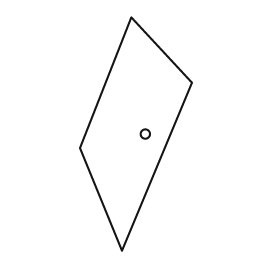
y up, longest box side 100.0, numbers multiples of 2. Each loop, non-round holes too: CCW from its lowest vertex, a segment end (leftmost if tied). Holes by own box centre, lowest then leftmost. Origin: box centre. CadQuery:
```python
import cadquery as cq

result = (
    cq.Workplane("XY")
    .moveTo(-6.0, -50.0)
    .lineTo(24.0, 22.0)
    .lineTo(-2.0, 50.0)
    .lineTo(-24.0, -6.0)
    .close()
    .moveTo(4.0, 0.0)
    .circle(2.0)
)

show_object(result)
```